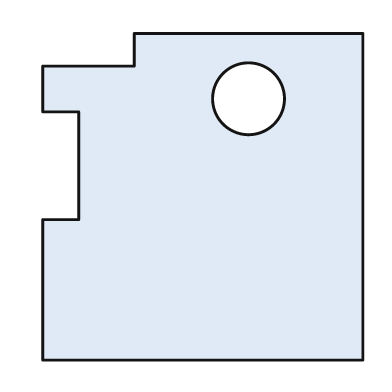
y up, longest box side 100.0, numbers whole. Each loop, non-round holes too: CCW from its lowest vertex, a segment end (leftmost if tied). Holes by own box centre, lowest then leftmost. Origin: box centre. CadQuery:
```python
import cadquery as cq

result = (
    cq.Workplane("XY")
    .moveTo(-49.0, -50.0)
    .lineTo(49.0, -50.0)
    .lineTo(49.0, 50.0)
    .lineTo(-21.0, 50.0)
    .lineTo(-21.0, 40.0)
    .lineTo(-49.0, 40.0)
    .lineTo(-49.0, 26.0)
    .lineTo(-38.0, 26.0)
    .lineTo(-38.0, -7.0)
    .lineTo(-49.0, -7.0)
    .close()
    .moveTo(14.0, 30.0)
    .circle(11.0)
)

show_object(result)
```